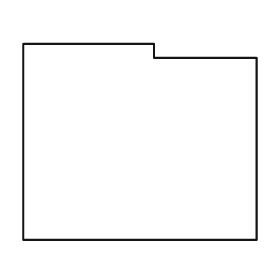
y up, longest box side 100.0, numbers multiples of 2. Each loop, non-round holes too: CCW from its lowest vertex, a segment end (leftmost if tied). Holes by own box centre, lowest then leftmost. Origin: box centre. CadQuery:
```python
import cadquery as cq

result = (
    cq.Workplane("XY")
    .moveTo(-50.0, -42.0)
    .lineTo(50.0, -42.0)
    .lineTo(50.0, 36.0)
    .lineTo(6.0, 36.0)
    .lineTo(6.0, 42.0)
    .lineTo(-50.0, 42.0)
    .close()
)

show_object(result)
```